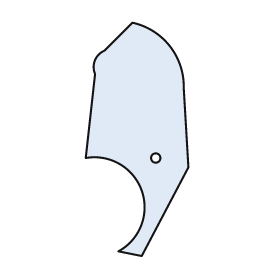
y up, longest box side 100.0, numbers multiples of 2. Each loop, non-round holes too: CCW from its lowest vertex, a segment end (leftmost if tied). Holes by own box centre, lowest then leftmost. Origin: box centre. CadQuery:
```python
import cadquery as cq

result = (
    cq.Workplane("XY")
    .moveTo(2.0, -50.0)
    .lineTo(22.0, -12.0)
    .lineTo(20.0, 22.0)
    .threePointArc((14.0, 40.0), (-2.0, 50.0))
    .lineTo(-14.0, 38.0)
    .threePointArc((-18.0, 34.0), (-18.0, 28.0))
    .lineTo(-22.0, -8.0)
    .threePointArc((2.0, -22.0), (-8.0, -48.0))
    .close()
    .moveTo(8.0, -8.0)
    .circle(2.0)
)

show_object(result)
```